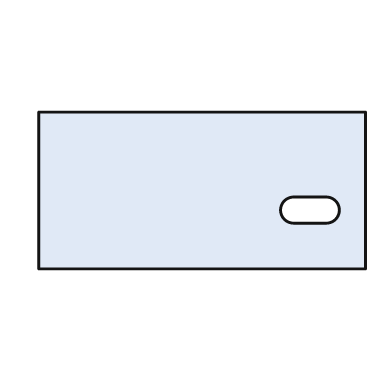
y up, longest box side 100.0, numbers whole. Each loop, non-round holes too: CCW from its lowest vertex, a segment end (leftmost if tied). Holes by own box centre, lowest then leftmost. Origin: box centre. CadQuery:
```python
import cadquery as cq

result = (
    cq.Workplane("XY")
    .moveTo(-50.0, -24.0)
    .lineTo(50.0, -24.0)
    .lineTo(50.0, 24.0)
    .lineTo(-50.0, 24.0)
    .close()
    .moveTo(28.0, -10.0)
    .lineTo(38.0, -10.0)
    .threePointArc((42.0, -6.0), (38.0, -2.0))
    .lineTo(28.0, -2.0)
    .threePointArc((24.0, -6.0), (28.0, -10.0))
    .close()
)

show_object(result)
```